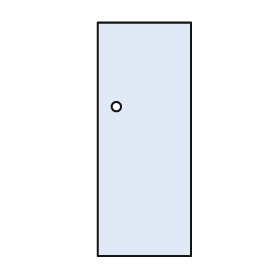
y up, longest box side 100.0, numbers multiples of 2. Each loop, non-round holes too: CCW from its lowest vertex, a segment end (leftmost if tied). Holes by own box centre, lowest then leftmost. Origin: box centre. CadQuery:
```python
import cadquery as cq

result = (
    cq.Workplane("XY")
    .moveTo(-20.0, -50.0)
    .lineTo(20.0, -50.0)
    .lineTo(20.0, 50.0)
    .lineTo(-20.0, 50.0)
    .close()
    .moveTo(-12.0, 14.0)
    .circle(2.0)
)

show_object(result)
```